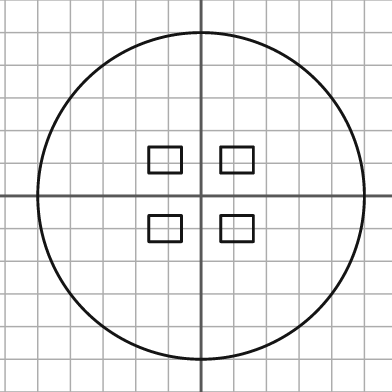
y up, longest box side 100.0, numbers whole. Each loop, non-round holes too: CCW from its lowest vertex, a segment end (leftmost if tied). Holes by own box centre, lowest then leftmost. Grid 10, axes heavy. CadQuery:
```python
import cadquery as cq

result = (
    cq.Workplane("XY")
    .moveTo(0.0, 0.0)
    .circle(50.0)
    .moveTo(-16.0, -14.0)
    .lineTo(-6.0, -14.0)
    .lineTo(-6.0, -6.0)
    .lineTo(-16.0, -6.0)
    .close()
    .moveTo(6.0, -14.0)
    .lineTo(16.0, -14.0)
    .lineTo(16.0, -6.0)
    .lineTo(6.0, -6.0)
    .close()
    .moveTo(-16.0, 7.0)
    .lineTo(-6.0, 7.0)
    .lineTo(-6.0, 15.0)
    .lineTo(-16.0, 15.0)
    .close()
    .moveTo(6.0, 7.0)
    .lineTo(16.0, 7.0)
    .lineTo(16.0, 15.0)
    .lineTo(6.0, 15.0)
    .close()
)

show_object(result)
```